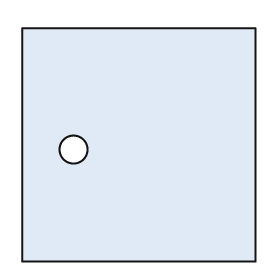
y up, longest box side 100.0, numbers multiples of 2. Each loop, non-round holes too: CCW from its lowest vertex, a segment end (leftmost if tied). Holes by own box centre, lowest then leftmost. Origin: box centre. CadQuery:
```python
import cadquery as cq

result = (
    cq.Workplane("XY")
    .moveTo(-50.0, -50.0)
    .lineTo(50.0, -50.0)
    .lineTo(50.0, 50.0)
    .lineTo(-50.0, 50.0)
    .close()
    .moveTo(-28.0, -2.0)
    .circle(6.0)
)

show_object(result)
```